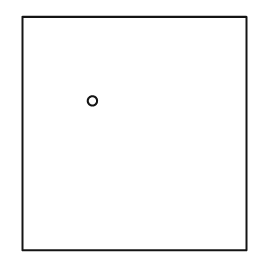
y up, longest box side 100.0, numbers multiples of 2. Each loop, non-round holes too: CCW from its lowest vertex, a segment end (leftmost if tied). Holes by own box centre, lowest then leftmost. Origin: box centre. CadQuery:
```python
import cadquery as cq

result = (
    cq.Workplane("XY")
    .moveTo(-48.0, -50.0)
    .lineTo(48.0, -50.0)
    .lineTo(48.0, 50.0)
    .lineTo(-48.0, 50.0)
    .close()
    .moveTo(-18.0, 14.0)
    .circle(2.0)
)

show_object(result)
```